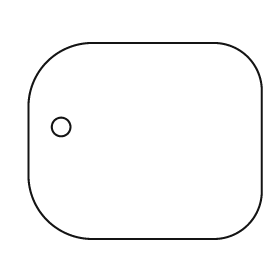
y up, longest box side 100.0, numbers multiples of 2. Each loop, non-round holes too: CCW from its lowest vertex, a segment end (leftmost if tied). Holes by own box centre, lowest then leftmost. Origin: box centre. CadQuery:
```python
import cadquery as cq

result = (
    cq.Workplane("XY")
    .moveTo(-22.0, -42.0)
    .lineTo(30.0, -42.0)
    .threePointArc((44.0, -36.0), (50.0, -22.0))
    .lineTo(50.0, 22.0)
    .threePointArc((44.0, 36.0), (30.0, 42.0))
    .lineTo(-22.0, 42.0)
    .threePointArc((-42.0, 34.0), (-50.0, 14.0))
    .lineTo(-50.0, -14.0)
    .threePointArc((-42.0, -34.0), (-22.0, -42.0))
    .close()
    .moveTo(-36.0, 6.0)
    .circle(4.0)
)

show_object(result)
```